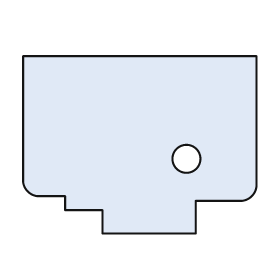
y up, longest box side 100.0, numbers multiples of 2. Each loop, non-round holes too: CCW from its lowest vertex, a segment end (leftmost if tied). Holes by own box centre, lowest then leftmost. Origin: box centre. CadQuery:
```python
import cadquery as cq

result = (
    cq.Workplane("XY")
    .moveTo(-16.0, -38.0)
    .lineTo(24.0, -38.0)
    .lineTo(24.0, -24.0)
    .lineTo(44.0, -24.0)
    .threePointArc((48.0, -22.0), (50.0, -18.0))
    .lineTo(50.0, 38.0)
    .lineTo(-50.0, 38.0)
    .lineTo(-50.0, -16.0)
    .threePointArc((-48.0, -20.0), (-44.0, -22.0))
    .lineTo(-32.0, -22.0)
    .lineTo(-32.0, -28.0)
    .lineTo(-16.0, -28.0)
    .close()
    .moveTo(20.0, -6.0)
    .circle(6.0)
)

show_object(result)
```